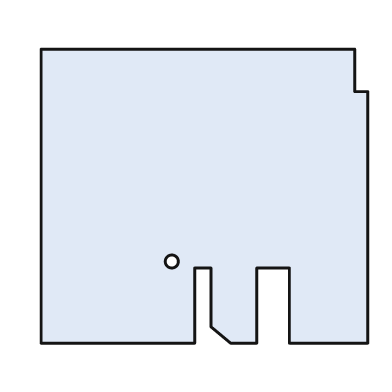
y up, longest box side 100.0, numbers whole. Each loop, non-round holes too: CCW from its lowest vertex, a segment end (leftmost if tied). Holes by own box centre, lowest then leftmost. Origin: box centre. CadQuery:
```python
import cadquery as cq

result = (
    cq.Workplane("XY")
    .moveTo(-50.0, -45.0)
    .lineTo(-3.0, -45.0)
    .lineTo(-3.0, -22.0)
    .lineTo(2.0, -22.0)
    .lineTo(2.0, -40.0)
    .lineTo(8.0, -45.0)
    .lineTo(16.0, -45.0)
    .lineTo(16.0, -22.0)
    .lineTo(26.0, -22.0)
    .lineTo(26.0, -45.0)
    .lineTo(50.0, -45.0)
    .lineTo(50.0, 32.0)
    .lineTo(46.0, 32.0)
    .lineTo(46.0, 45.0)
    .lineTo(-50.0, 45.0)
    .close()
    .moveTo(-10.0, -20.0)
    .circle(2.0)
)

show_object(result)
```